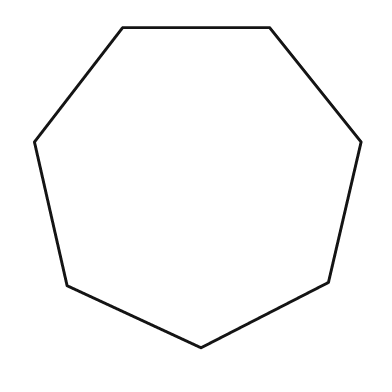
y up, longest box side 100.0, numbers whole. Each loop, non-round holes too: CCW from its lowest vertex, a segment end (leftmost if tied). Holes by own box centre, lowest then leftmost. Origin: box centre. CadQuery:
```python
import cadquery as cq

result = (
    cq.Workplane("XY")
    .moveTo(1.0, -49.0)
    .lineTo(40.0, -29.0)
    .lineTo(50.0, 14.0)
    .lineTo(22.0, 49.0)
    .lineTo(-23.0, 49.0)
    .lineTo(-50.0, 14.0)
    .lineTo(-40.0, -30.0)
    .close()
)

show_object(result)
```